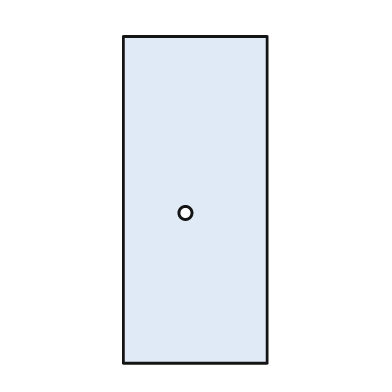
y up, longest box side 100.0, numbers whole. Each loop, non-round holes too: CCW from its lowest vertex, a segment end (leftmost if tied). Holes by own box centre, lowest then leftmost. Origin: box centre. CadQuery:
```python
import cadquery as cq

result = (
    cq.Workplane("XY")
    .moveTo(-22.0, -50.0)
    .lineTo(22.0, -50.0)
    .lineTo(22.0, 50.0)
    .lineTo(-22.0, 50.0)
    .close()
    .moveTo(-3.0, -4.0)
    .circle(2.0)
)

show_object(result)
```